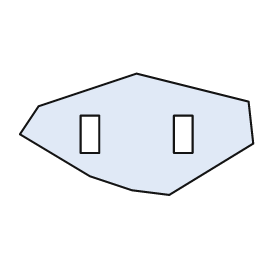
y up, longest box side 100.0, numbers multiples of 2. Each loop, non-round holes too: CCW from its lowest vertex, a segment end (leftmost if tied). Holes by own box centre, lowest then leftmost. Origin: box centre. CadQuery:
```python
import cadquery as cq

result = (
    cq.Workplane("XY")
    .moveTo(14.0, -26.0)
    .lineTo(50.0, -4.0)
    .lineTo(48.0, 14.0)
    .lineTo(0.0, 26.0)
    .lineTo(-42.0, 12.0)
    .lineTo(-50.0, 0.0)
    .lineTo(-20.0, -18.0)
    .lineTo(-2.0, -24.0)
    .close()
    .moveTo(-24.0, -8.0)
    .lineTo(-16.0, -8.0)
    .lineTo(-16.0, 8.0)
    .lineTo(-24.0, 8.0)
    .close()
    .moveTo(16.0, -8.0)
    .lineTo(24.0, -8.0)
    .lineTo(24.0, 8.0)
    .lineTo(16.0, 8.0)
    .close()
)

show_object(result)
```